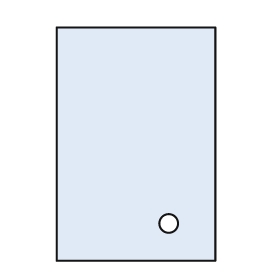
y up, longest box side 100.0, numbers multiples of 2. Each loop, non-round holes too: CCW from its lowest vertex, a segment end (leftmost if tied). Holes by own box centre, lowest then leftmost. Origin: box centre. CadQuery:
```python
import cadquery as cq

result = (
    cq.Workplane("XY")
    .moveTo(-34.0, -50.0)
    .lineTo(34.0, -50.0)
    .lineTo(34.0, 50.0)
    .lineTo(-34.0, 50.0)
    .close()
    .moveTo(14.0, -34.0)
    .circle(4.0)
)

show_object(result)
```